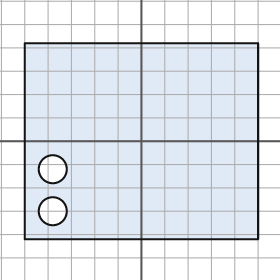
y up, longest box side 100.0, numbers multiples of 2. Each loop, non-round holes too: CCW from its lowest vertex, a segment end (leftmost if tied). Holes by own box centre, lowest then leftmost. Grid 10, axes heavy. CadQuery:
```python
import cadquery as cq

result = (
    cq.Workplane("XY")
    .moveTo(-50.0, -42.0)
    .lineTo(50.0, -42.0)
    .lineTo(50.0, 42.0)
    .lineTo(-50.0, 42.0)
    .close()
    .moveTo(-38.0, -30.0)
    .circle(6.0)
    .moveTo(-38.0, -12.0)
    .circle(6.0)
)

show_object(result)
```